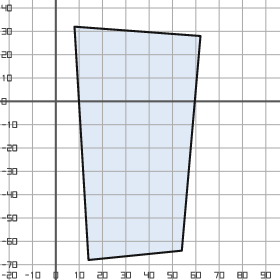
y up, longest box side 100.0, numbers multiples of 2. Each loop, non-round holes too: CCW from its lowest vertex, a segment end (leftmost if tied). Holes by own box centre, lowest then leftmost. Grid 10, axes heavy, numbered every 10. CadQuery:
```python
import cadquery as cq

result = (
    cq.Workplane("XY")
    .moveTo(14.0, -68.0)
    .lineTo(54.0, -64.0)
    .lineTo(62.0, 28.0)
    .lineTo(8.0, 32.0)
    .close()
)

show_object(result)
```